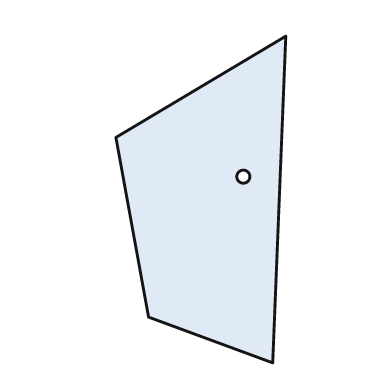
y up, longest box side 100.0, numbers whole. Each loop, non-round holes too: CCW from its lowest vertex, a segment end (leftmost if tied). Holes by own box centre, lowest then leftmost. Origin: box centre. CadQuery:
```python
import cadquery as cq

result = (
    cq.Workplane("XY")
    .moveTo(22.0, -50.0)
    .lineTo(26.0, 50.0)
    .lineTo(-26.0, 19.0)
    .lineTo(-16.0, -36.0)
    .close()
    .moveTo(13.0, 7.0)
    .circle(2.0)
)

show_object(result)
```